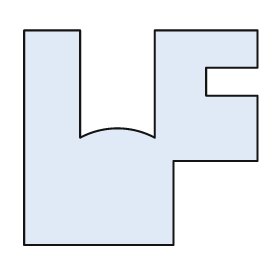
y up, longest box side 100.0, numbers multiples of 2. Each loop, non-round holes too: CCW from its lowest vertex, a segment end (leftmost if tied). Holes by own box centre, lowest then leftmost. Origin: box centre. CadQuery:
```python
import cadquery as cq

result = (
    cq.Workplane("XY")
    .moveTo(-50.0, -46.0)
    .lineTo(14.0, -46.0)
    .lineTo(14.0, -10.0)
    .lineTo(50.0, -10.0)
    .lineTo(50.0, 18.0)
    .lineTo(28.0, 18.0)
    .lineTo(28.0, 30.0)
    .lineTo(50.0, 30.0)
    .lineTo(50.0, 46.0)
    .lineTo(6.0, 46.0)
    .lineTo(6.0, 0.0)
    .threePointArc((-10.0, 4.0), (-26.0, 0.0))
    .lineTo(-26.0, 46.0)
    .lineTo(-50.0, 46.0)
    .close()
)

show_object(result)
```